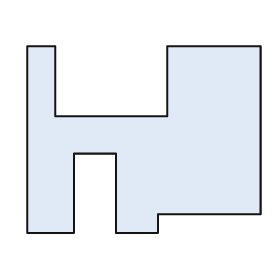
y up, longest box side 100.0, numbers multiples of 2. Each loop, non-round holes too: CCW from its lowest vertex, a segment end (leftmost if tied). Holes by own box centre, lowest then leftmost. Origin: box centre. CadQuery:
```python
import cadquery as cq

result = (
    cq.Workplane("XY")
    .moveTo(-50.0, -40.0)
    .lineTo(-30.0, -40.0)
    .lineTo(-30.0, -6.0)
    .lineTo(-12.0, -6.0)
    .lineTo(-12.0, -40.0)
    .lineTo(6.0, -40.0)
    .lineTo(6.0, -32.0)
    .lineTo(50.0, -32.0)
    .lineTo(50.0, 40.0)
    .lineTo(10.0, 40.0)
    .lineTo(10.0, 10.0)
    .lineTo(-38.0, 10.0)
    .lineTo(-38.0, 40.0)
    .lineTo(-50.0, 40.0)
    .close()
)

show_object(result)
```